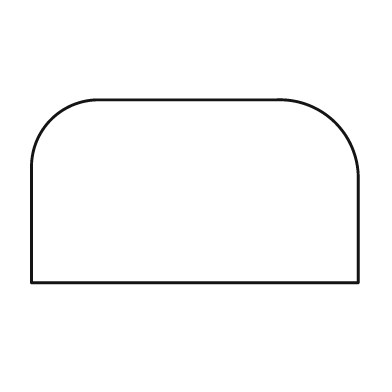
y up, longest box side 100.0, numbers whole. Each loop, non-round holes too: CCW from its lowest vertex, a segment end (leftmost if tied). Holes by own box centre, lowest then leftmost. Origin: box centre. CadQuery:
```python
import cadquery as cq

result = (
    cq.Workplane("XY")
    .moveTo(-50.0, -28.0)
    .lineTo(50.0, -28.0)
    .lineTo(50.0, 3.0)
    .threePointArc((43.0, 21.0), (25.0, 28.0))
    .lineTo(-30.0, 28.0)
    .threePointArc((-44.0, 22.0), (-50.0, 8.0))
    .close()
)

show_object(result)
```